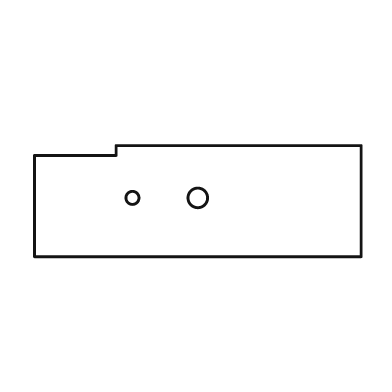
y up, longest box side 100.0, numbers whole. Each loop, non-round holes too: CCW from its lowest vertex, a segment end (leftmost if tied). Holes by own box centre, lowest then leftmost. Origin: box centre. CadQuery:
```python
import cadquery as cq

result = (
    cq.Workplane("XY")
    .moveTo(-50.0, -17.0)
    .lineTo(50.0, -17.0)
    .lineTo(50.0, 17.0)
    .lineTo(-25.0, 17.0)
    .lineTo(-25.0, 14.0)
    .lineTo(-50.0, 14.0)
    .close()
    .moveTo(-20.0, 1.0)
    .circle(2.0)
    .moveTo(0.0, 1.0)
    .circle(3.0)
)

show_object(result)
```